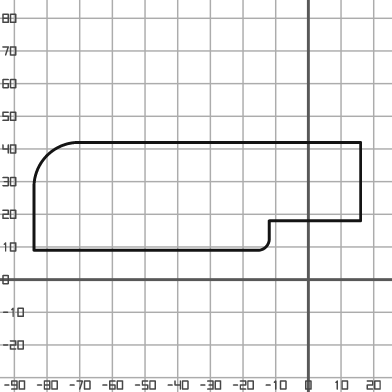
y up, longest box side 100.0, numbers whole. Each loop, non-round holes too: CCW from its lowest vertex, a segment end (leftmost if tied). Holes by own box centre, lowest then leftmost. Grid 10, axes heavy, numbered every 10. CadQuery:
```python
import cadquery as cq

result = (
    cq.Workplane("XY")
    .moveTo(-84.0, 9.0)
    .lineTo(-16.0, 9.0)
    .threePointArc((-13.0, 10.0), (-12.0, 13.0))
    .lineTo(-12.0, 18.0)
    .lineTo(16.0, 18.0)
    .lineTo(16.0, 42.0)
    .lineTo(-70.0, 42.0)
    .threePointArc((-80.0, 38.0), (-84.0, 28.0))
    .close()
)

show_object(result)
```